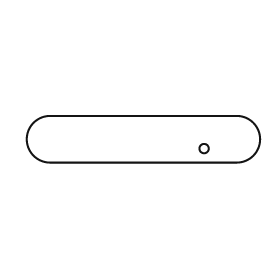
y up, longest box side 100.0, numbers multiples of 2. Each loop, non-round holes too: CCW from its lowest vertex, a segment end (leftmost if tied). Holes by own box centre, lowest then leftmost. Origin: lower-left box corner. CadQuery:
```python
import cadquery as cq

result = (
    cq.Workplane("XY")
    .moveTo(10.0, 0.0)
    .lineTo(90.0, 0.0)
    .threePointArc((100.0, 10.0), (90.0, 20.0))
    .lineTo(10.0, 20.0)
    .threePointArc((0.0, 10.0), (10.0, 0.0))
    .close()
    .moveTo(76.0, 6.0)
    .circle(2.0)
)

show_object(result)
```